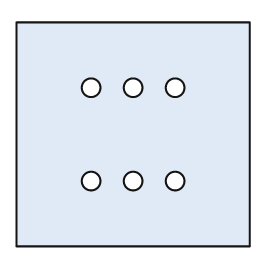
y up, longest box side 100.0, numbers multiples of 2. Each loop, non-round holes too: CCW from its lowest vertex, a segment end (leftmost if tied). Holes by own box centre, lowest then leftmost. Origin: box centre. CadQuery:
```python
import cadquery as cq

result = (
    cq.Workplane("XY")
    .moveTo(-50.0, -48.0)
    .lineTo(50.0, -48.0)
    .lineTo(50.0, 48.0)
    .lineTo(-50.0, 48.0)
    .close()
    .moveTo(-18.0, -20.0)
    .circle(4.0)
    .moveTo(0.0, -20.0)
    .circle(4.0)
    .moveTo(18.0, -20.0)
    .circle(4.0)
    .moveTo(-18.0, 20.0)
    .circle(4.0)
    .moveTo(0.0, 20.0)
    .circle(4.0)
    .moveTo(18.0, 20.0)
    .circle(4.0)
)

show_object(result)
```